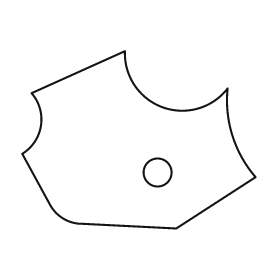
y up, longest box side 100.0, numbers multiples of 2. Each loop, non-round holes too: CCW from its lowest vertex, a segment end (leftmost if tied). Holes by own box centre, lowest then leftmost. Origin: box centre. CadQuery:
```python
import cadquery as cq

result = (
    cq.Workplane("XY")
    .moveTo(16.0, -38.0)
    .lineTo(50.0, -16.0)
    .threePointArc((40.0, 2.0), (38.0, 22.0))
    .threePointArc((10.0, 14.0), (-6.0, 38.0))
    .lineTo(-46.0, 20.0)
    .threePointArc((-42.0, 6.0), (-50.0, -6.0))
    .lineTo(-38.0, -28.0)
    .threePointArc((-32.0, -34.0), (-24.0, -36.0))
    .close()
    .moveTo(8.0, -14.0)
    .circle(6.0)
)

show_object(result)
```